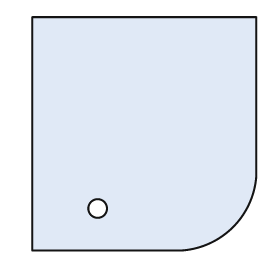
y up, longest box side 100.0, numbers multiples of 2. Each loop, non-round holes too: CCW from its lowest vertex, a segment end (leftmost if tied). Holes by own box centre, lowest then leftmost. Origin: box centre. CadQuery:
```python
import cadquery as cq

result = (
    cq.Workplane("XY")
    .moveTo(-48.0, -50.0)
    .lineTo(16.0, -50.0)
    .threePointArc((38.0, -40.0), (48.0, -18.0))
    .lineTo(48.0, 50.0)
    .lineTo(-48.0, 50.0)
    .close()
    .moveTo(-20.0, -32.0)
    .circle(4.0)
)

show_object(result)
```